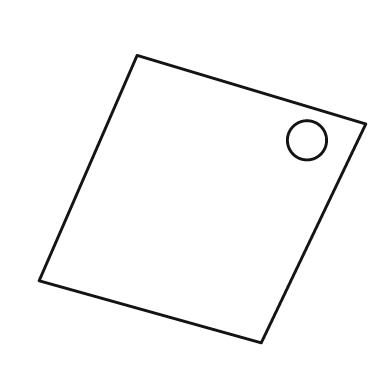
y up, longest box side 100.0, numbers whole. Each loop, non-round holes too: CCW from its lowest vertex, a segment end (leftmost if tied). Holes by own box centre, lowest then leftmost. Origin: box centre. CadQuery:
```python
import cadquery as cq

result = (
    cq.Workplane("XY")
    .moveTo(18.0, -44.0)
    .lineTo(50.0, 23.0)
    .lineTo(-20.0, 44.0)
    .lineTo(-50.0, -25.0)
    .close()
    .moveTo(32.0, 18.0)
    .circle(6.0)
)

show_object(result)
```